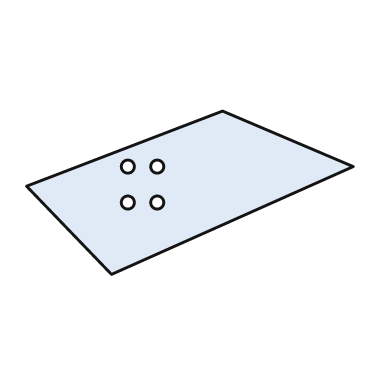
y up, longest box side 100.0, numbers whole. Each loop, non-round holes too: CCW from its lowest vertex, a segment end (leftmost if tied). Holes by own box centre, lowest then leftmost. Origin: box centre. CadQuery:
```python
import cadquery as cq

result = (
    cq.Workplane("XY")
    .moveTo(-24.0, -25.0)
    .lineTo(50.0, 8.0)
    .lineTo(10.0, 25.0)
    .lineTo(-50.0, 2.0)
    .close()
    .moveTo(-19.0, -3.0)
    .circle(2.0)
    .moveTo(-10.0, -3.0)
    .circle(2.0)
    .moveTo(-19.0, 8.0)
    .circle(2.0)
    .moveTo(-10.0, 8.0)
    .circle(2.0)
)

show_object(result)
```